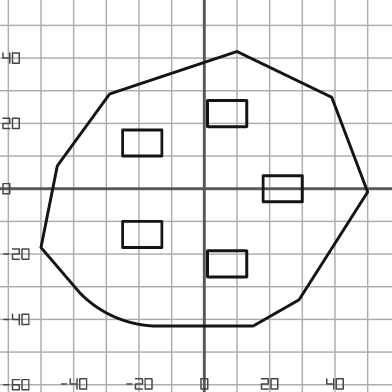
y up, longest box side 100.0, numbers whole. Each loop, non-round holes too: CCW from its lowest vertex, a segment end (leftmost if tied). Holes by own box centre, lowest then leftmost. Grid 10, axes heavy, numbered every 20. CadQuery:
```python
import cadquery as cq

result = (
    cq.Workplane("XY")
    .moveTo(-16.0, -42.0)
    .lineTo(15.0, -42.0)
    .lineTo(29.0, -34.0)
    .lineTo(50.0, -1.0)
    .lineTo(39.0, 28.0)
    .lineTo(10.0, 42.0)
    .lineTo(-29.0, 29.0)
    .lineTo(-45.0, 7.0)
    .lineTo(-50.0, -18.0)
    .lineTo(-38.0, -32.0)
    .threePointArc((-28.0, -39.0), (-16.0, -42.0))
    .close()
    .moveTo(1.0, -27.0)
    .lineTo(13.0, -27.0)
    .lineTo(13.0, -19.0)
    .lineTo(1.0, -19.0)
    .close()
    .moveTo(-25.0, -18.0)
    .lineTo(-13.0, -18.0)
    .lineTo(-13.0, -10.0)
    .lineTo(-25.0, -10.0)
    .close()
    .moveTo(18.0, -4.0)
    .lineTo(30.0, -4.0)
    .lineTo(30.0, 4.0)
    .lineTo(18.0, 4.0)
    .close()
    .moveTo(-25.0, 10.0)
    .lineTo(-13.0, 10.0)
    .lineTo(-13.0, 18.0)
    .lineTo(-25.0, 18.0)
    .close()
    .moveTo(1.0, 19.0)
    .lineTo(13.0, 19.0)
    .lineTo(13.0, 27.0)
    .lineTo(1.0, 27.0)
    .close()
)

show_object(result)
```